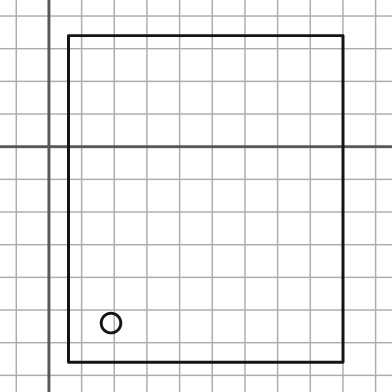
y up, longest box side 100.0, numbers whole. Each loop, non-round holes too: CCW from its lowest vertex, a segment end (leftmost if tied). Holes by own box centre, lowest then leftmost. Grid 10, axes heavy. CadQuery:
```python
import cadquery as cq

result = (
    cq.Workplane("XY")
    .moveTo(6.0, -66.0)
    .lineTo(90.0, -66.0)
    .lineTo(90.0, 34.0)
    .lineTo(6.0, 34.0)
    .close()
    .moveTo(19.0, -54.0)
    .circle(3.0)
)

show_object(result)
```